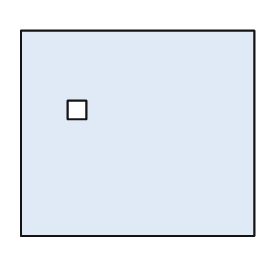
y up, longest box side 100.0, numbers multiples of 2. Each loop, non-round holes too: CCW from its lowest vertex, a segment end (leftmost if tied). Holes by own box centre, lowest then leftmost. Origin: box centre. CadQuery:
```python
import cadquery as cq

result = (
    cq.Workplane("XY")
    .moveTo(-50.0, -44.0)
    .lineTo(50.0, -44.0)
    .lineTo(50.0, 44.0)
    .lineTo(-50.0, 44.0)
    .close()
    .moveTo(-30.0, 6.0)
    .lineTo(-22.0, 6.0)
    .lineTo(-22.0, 14.0)
    .lineTo(-30.0, 14.0)
    .close()
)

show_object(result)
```